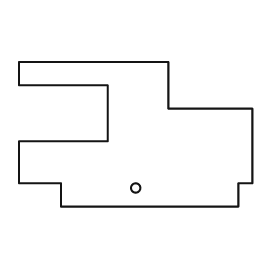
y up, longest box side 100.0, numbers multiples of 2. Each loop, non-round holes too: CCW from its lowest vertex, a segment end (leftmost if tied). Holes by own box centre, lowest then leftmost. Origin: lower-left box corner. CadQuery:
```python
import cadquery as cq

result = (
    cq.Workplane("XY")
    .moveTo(18.0, 0.0)
    .lineTo(94.0, 0.0)
    .lineTo(94.0, 10.0)
    .lineTo(100.0, 10.0)
    .lineTo(100.0, 42.0)
    .lineTo(64.0, 42.0)
    .lineTo(64.0, 62.0)
    .lineTo(0.0, 62.0)
    .lineTo(0.0, 52.0)
    .lineTo(38.0, 52.0)
    .lineTo(38.0, 28.0)
    .lineTo(0.0, 28.0)
    .lineTo(0.0, 10.0)
    .lineTo(18.0, 10.0)
    .close()
    .moveTo(50.0, 8.0)
    .circle(2.0)
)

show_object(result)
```